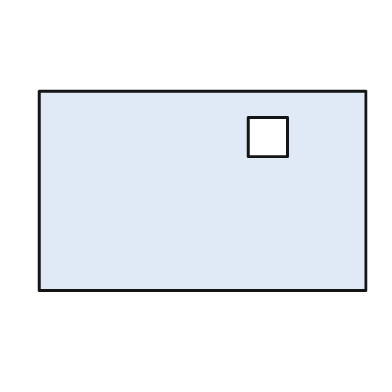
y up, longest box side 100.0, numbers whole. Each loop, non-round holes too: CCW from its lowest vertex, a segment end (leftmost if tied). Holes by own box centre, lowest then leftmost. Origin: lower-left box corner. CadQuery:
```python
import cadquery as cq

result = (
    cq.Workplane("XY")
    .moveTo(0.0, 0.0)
    .lineTo(100.0, 0.0)
    .lineTo(100.0, 61.0)
    .lineTo(0.0, 61.0)
    .close()
    .moveTo(64.0, 41.0)
    .lineTo(76.0, 41.0)
    .lineTo(76.0, 53.0)
    .lineTo(64.0, 53.0)
    .close()
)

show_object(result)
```